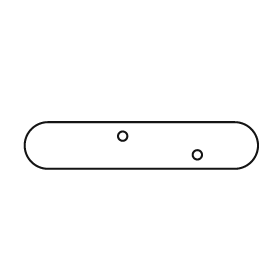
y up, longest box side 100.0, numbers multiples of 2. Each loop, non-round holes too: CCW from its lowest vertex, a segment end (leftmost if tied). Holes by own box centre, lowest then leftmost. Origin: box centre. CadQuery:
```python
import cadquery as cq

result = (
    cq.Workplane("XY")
    .moveTo(-40.0, -10.0)
    .lineTo(40.0, -10.0)
    .threePointArc((50.0, 0.0), (40.0, 10.0))
    .lineTo(-40.0, 10.0)
    .threePointArc((-50.0, 0.0), (-40.0, -10.0))
    .close()
    .moveTo(24.0, -4.0)
    .circle(2.0)
    .moveTo(-8.0, 4.0)
    .circle(2.0)
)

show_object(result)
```